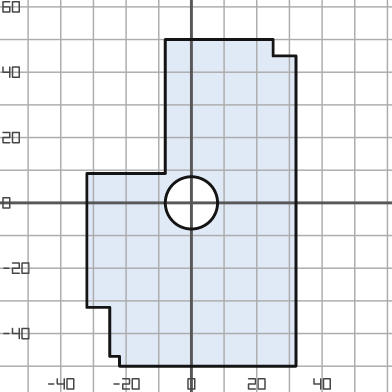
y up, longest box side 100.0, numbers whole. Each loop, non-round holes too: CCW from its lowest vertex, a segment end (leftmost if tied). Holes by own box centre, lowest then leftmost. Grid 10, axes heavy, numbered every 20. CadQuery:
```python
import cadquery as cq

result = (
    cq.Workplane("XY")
    .moveTo(-22.0, -50.0)
    .lineTo(32.0, -50.0)
    .lineTo(32.0, 45.0)
    .lineTo(25.0, 45.0)
    .lineTo(25.0, 50.0)
    .lineTo(-8.0, 50.0)
    .lineTo(-8.0, 9.0)
    .lineTo(-32.0, 9.0)
    .lineTo(-32.0, -32.0)
    .lineTo(-25.0, -32.0)
    .lineTo(-25.0, -47.0)
    .lineTo(-22.0, -47.0)
    .close()
    .moveTo(0.0, 0.0)
    .circle(8.0)
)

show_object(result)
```